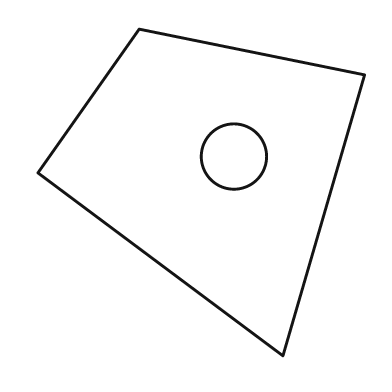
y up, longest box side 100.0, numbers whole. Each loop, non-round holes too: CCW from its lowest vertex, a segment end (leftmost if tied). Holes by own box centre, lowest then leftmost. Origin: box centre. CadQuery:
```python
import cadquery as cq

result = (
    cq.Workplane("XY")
    .moveTo(25.0, -50.0)
    .lineTo(50.0, 36.0)
    .lineTo(-19.0, 50.0)
    .lineTo(-50.0, 6.0)
    .close()
    .moveTo(10.0, 11.0)
    .circle(10.0)
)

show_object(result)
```